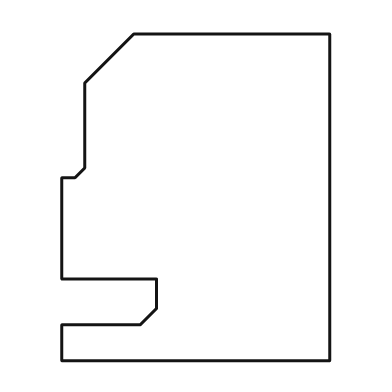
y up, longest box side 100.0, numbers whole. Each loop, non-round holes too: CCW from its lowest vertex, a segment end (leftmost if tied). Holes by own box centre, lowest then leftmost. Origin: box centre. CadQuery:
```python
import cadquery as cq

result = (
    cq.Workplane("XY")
    .moveTo(-41.0, -50.0)
    .lineTo(41.0, -50.0)
    .lineTo(41.0, 50.0)
    .lineTo(-19.0, 50.0)
    .lineTo(-34.0, 35.0)
    .lineTo(-34.0, 9.0)
    .lineTo(-37.0, 6.0)
    .lineTo(-41.0, 6.0)
    .lineTo(-41.0, -25.0)
    .lineTo(-12.0, -25.0)
    .lineTo(-12.0, -34.0)
    .lineTo(-17.0, -39.0)
    .lineTo(-41.0, -39.0)
    .close()
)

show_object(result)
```